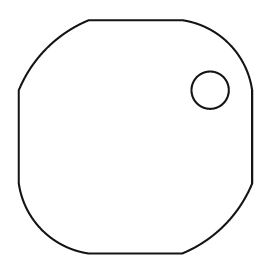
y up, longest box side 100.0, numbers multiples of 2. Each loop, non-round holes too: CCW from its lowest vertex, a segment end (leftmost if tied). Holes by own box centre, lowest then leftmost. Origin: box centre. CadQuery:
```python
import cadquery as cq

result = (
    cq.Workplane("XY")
    .moveTo(-20.0, -50.0)
    .lineTo(20.0, -50.0)
    .threePointArc((38.0, -38.0), (50.0, -20.0))
    .lineTo(50.0, 20.0)
    .threePointArc((40.0, 40.0), (20.0, 50.0))
    .lineTo(-20.0, 50.0)
    .threePointArc((-38.0, 38.0), (-50.0, 20.0))
    .lineTo(-50.0, -20.0)
    .threePointArc((-40.0, -40.0), (-20.0, -50.0))
    .close()
    .moveTo(32.0, 20.0)
    .circle(8.0)
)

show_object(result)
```